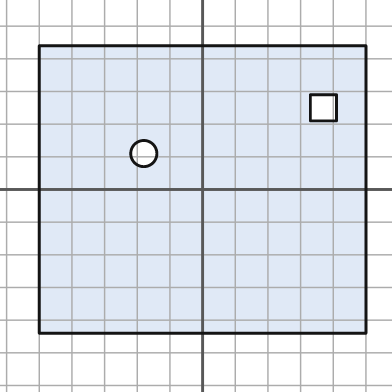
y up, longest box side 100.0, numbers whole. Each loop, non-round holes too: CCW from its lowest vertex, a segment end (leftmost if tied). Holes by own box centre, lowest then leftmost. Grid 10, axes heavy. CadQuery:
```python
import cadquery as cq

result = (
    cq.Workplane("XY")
    .moveTo(-50.0, -44.0)
    .lineTo(50.0, -44.0)
    .lineTo(50.0, 44.0)
    .lineTo(-50.0, 44.0)
    .close()
    .moveTo(-18.0, 11.0)
    .circle(4.0)
    .moveTo(33.0, 21.0)
    .lineTo(41.0, 21.0)
    .lineTo(41.0, 29.0)
    .lineTo(33.0, 29.0)
    .close()
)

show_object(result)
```